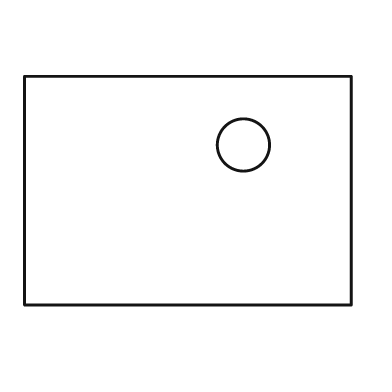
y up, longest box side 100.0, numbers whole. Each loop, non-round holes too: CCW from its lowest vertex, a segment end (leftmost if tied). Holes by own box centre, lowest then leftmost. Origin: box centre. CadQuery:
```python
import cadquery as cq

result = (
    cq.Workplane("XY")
    .moveTo(-50.0, -35.0)
    .lineTo(50.0, -35.0)
    .lineTo(50.0, 35.0)
    .lineTo(-50.0, 35.0)
    .close()
    .moveTo(17.0, 14.0)
    .circle(8.0)
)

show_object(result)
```